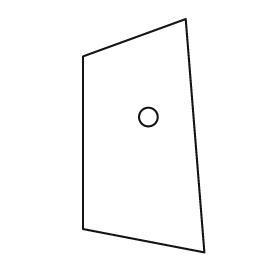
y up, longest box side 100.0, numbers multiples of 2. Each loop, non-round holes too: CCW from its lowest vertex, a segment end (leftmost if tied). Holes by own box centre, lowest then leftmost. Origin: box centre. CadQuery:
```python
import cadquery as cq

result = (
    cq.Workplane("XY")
    .moveTo(26.0, -50.0)
    .lineTo(18.0, 50.0)
    .lineTo(-26.0, 34.0)
    .lineTo(-26.0, -40.0)
    .close()
    .moveTo(2.0, 8.0)
    .circle(4.0)
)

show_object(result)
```